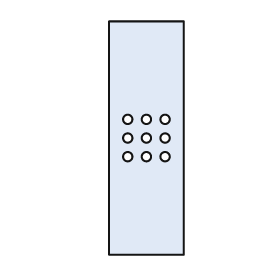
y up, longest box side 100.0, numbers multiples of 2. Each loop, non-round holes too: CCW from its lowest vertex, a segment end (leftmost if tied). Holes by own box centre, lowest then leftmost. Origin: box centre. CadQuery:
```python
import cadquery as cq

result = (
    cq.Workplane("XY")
    .moveTo(-16.0, -50.0)
    .lineTo(16.0, -50.0)
    .lineTo(16.0, 50.0)
    .lineTo(-16.0, 50.0)
    .close()
    .moveTo(-8.0, -8.0)
    .circle(2.0)
    .moveTo(0.0, -8.0)
    .circle(2.0)
    .moveTo(8.0, -8.0)
    .circle(2.0)
    .moveTo(-8.0, 0.0)
    .circle(2.0)
    .moveTo(0.0, 0.0)
    .circle(2.0)
    .moveTo(8.0, 0.0)
    .circle(2.0)
    .moveTo(-8.0, 8.0)
    .circle(2.0)
    .moveTo(0.0, 8.0)
    .circle(2.0)
    .moveTo(8.0, 8.0)
    .circle(2.0)
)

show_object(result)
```